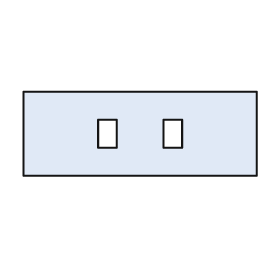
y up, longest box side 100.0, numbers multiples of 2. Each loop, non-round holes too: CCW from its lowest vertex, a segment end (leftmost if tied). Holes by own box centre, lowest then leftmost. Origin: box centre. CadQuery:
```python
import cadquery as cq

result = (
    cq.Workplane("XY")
    .moveTo(-50.0, -18.0)
    .lineTo(50.0, -18.0)
    .lineTo(50.0, 18.0)
    .lineTo(-50.0, 18.0)
    .close()
    .moveTo(-18.0, -6.0)
    .lineTo(-10.0, -6.0)
    .lineTo(-10.0, 6.0)
    .lineTo(-18.0, 6.0)
    .close()
    .moveTo(10.0, -6.0)
    .lineTo(18.0, -6.0)
    .lineTo(18.0, 6.0)
    .lineTo(10.0, 6.0)
    .close()
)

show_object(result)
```